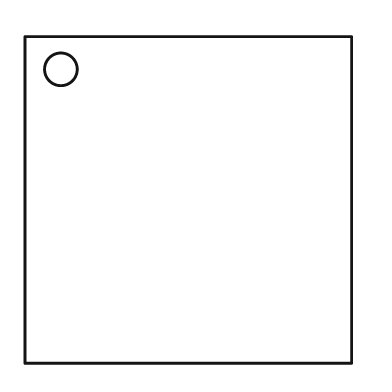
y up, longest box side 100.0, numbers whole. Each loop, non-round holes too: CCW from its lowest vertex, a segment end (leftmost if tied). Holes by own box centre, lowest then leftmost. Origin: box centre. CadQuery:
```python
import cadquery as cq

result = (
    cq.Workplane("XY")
    .moveTo(-50.0, -50.0)
    .lineTo(50.0, -50.0)
    .lineTo(50.0, 50.0)
    .lineTo(-50.0, 50.0)
    .close()
    .moveTo(-39.0, 40.0)
    .circle(5.0)
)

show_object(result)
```